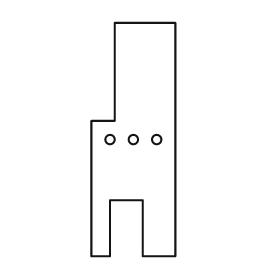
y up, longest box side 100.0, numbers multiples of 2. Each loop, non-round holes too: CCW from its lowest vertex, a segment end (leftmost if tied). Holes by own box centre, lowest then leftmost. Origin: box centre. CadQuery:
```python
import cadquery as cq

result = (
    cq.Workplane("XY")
    .moveTo(-18.0, -50.0)
    .lineTo(-10.0, -50.0)
    .lineTo(-10.0, -26.0)
    .lineTo(4.0, -26.0)
    .lineTo(4.0, -50.0)
    .lineTo(18.0, -50.0)
    .lineTo(18.0, 50.0)
    .lineTo(-8.0, 50.0)
    .lineTo(-8.0, 8.0)
    .lineTo(-18.0, 8.0)
    .close()
    .moveTo(-10.0, 0.0)
    .circle(2.0)
    .moveTo(0.0, 0.0)
    .circle(2.0)
    .moveTo(10.0, 0.0)
    .circle(2.0)
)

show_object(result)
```